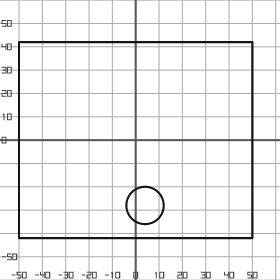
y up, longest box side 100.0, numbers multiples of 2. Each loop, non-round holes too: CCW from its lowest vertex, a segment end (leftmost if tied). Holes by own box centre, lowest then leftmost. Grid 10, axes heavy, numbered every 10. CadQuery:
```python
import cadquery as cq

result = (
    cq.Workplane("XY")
    .moveTo(-50.0, -42.0)
    .lineTo(50.0, -42.0)
    .lineTo(50.0, 42.0)
    .lineTo(-50.0, 42.0)
    .close()
    .moveTo(4.0, -28.0)
    .circle(8.0)
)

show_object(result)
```